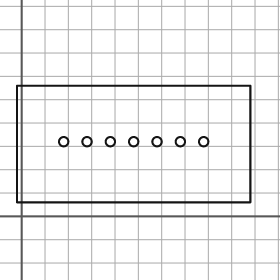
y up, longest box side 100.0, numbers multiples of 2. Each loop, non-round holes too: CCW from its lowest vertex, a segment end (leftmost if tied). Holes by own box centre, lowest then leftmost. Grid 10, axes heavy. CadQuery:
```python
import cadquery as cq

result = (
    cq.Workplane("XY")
    .moveTo(-2.0, 6.0)
    .lineTo(98.0, 6.0)
    .lineTo(98.0, 56.0)
    .lineTo(-2.0, 56.0)
    .close()
    .moveTo(18.0, 32.0)
    .circle(2.0)
    .moveTo(28.0, 32.0)
    .circle(2.0)
    .moveTo(38.0, 32.0)
    .circle(2.0)
    .moveTo(48.0, 32.0)
    .circle(2.0)
    .moveTo(58.0, 32.0)
    .circle(2.0)
    .moveTo(68.0, 32.0)
    .circle(2.0)
    .moveTo(78.0, 32.0)
    .circle(2.0)
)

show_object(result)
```